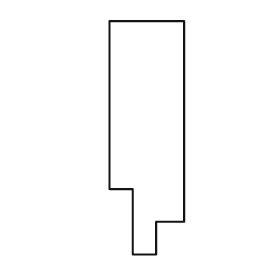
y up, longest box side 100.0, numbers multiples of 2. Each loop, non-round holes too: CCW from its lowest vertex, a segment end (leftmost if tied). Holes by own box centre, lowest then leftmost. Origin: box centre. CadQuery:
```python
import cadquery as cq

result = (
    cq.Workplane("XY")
    .moveTo(-6.0, -50.0)
    .lineTo(4.0, -50.0)
    .lineTo(4.0, -36.0)
    .lineTo(16.0, -36.0)
    .lineTo(16.0, 50.0)
    .lineTo(-16.0, 50.0)
    .lineTo(-16.0, -22.0)
    .lineTo(-6.0, -22.0)
    .close()
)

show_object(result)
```